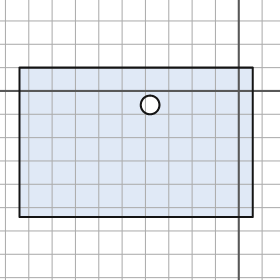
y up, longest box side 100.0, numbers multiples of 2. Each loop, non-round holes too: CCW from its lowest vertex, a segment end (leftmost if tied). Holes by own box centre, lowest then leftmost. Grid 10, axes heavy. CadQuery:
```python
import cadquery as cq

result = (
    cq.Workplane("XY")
    .moveTo(-94.0, -54.0)
    .lineTo(6.0, -54.0)
    .lineTo(6.0, 10.0)
    .lineTo(-94.0, 10.0)
    .close()
    .moveTo(-38.0, -6.0)
    .circle(4.0)
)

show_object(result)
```